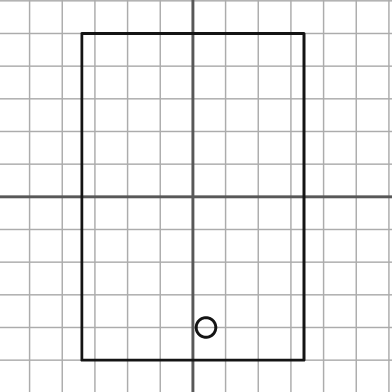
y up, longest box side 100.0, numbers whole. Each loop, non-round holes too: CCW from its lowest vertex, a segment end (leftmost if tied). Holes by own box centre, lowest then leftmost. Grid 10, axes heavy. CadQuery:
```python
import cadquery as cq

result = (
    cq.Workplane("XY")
    .moveTo(-34.0, -50.0)
    .lineTo(34.0, -50.0)
    .lineTo(34.0, 50.0)
    .lineTo(-34.0, 50.0)
    .close()
    .moveTo(4.0, -40.0)
    .circle(3.0)
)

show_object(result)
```